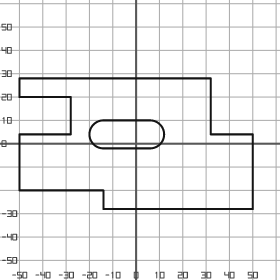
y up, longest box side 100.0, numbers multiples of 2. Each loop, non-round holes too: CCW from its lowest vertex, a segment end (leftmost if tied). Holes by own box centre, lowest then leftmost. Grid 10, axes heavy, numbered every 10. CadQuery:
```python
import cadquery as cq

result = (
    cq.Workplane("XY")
    .moveTo(-14.0, -28.0)
    .lineTo(50.0, -28.0)
    .lineTo(50.0, 4.0)
    .lineTo(32.0, 4.0)
    .lineTo(32.0, 28.0)
    .lineTo(-50.0, 28.0)
    .lineTo(-50.0, 20.0)
    .lineTo(-28.0, 20.0)
    .lineTo(-28.0, 4.0)
    .lineTo(-50.0, 4.0)
    .lineTo(-50.0, -20.0)
    .lineTo(-14.0, -20.0)
    .close()
    .moveTo(-14.0, -2.0)
    .lineTo(6.0, -2.0)
    .threePointArc((12.0, 4.0), (6.0, 10.0))
    .lineTo(-14.0, 10.0)
    .threePointArc((-20.0, 4.0), (-14.0, -2.0))
    .close()
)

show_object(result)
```